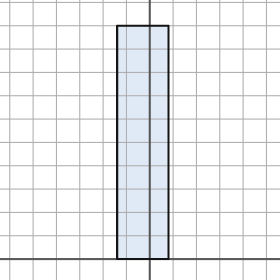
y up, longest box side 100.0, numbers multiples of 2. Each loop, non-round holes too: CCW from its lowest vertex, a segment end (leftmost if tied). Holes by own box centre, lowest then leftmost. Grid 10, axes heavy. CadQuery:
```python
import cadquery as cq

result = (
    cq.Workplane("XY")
    .moveTo(-14.0, 0.0)
    .lineTo(8.0, 0.0)
    .lineTo(8.0, 100.0)
    .lineTo(-14.0, 100.0)
    .close()
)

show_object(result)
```